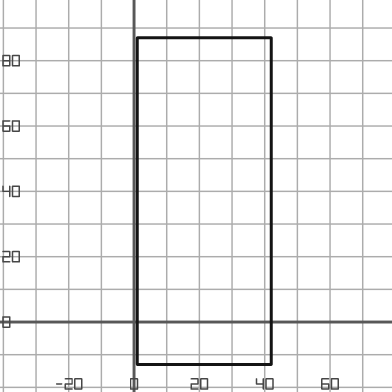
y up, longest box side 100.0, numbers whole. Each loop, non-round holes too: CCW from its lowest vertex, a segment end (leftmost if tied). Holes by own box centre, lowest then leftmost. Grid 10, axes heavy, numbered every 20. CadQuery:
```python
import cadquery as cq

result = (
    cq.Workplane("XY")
    .moveTo(1.0, -13.0)
    .lineTo(42.0, -13.0)
    .lineTo(42.0, 87.0)
    .lineTo(1.0, 87.0)
    .close()
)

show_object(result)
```